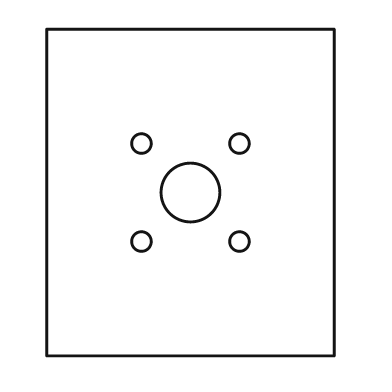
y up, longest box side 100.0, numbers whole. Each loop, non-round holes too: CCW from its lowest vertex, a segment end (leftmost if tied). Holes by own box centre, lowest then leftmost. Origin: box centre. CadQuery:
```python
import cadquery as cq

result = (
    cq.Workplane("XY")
    .moveTo(-44.0, -50.0)
    .lineTo(44.0, -50.0)
    .lineTo(44.0, 50.0)
    .lineTo(-44.0, 50.0)
    .close()
    .moveTo(-15.0, -15.0)
    .circle(3.0)
    .moveTo(15.0, -15.0)
    .circle(3.0)
    .moveTo(0.0, 0.0)
    .circle(9.0)
    .moveTo(-15.0, 15.0)
    .circle(3.0)
    .moveTo(15.0, 15.0)
    .circle(3.0)
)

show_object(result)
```